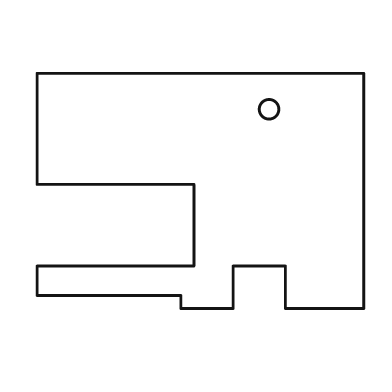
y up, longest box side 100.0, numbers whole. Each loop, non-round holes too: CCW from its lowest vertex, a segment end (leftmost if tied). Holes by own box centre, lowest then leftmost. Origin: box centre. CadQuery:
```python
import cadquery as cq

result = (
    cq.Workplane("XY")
    .moveTo(-6.0, -36.0)
    .lineTo(10.0, -36.0)
    .lineTo(10.0, -23.0)
    .lineTo(26.0, -23.0)
    .lineTo(26.0, -36.0)
    .lineTo(50.0, -36.0)
    .lineTo(50.0, 36.0)
    .lineTo(-50.0, 36.0)
    .lineTo(-50.0, 2.0)
    .lineTo(-2.0, 2.0)
    .lineTo(-2.0, -23.0)
    .lineTo(-50.0, -23.0)
    .lineTo(-50.0, -32.0)
    .lineTo(-6.0, -32.0)
    .close()
    .moveTo(21.0, 25.0)
    .circle(3.0)
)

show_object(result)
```